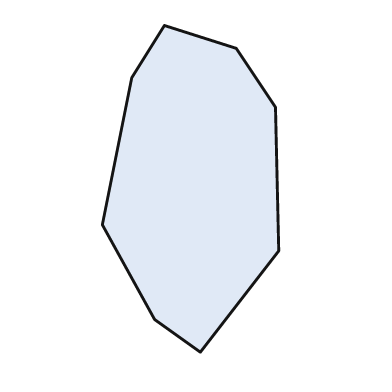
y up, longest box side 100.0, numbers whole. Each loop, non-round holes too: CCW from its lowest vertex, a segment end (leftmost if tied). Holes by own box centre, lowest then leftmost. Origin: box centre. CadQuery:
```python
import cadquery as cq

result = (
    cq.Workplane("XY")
    .moveTo(3.0, -50.0)
    .lineTo(27.0, -19.0)
    .lineTo(26.0, 25.0)
    .lineTo(14.0, 43.0)
    .lineTo(-8.0, 50.0)
    .lineTo(-18.0, 34.0)
    .lineTo(-27.0, -11.0)
    .lineTo(-11.0, -40.0)
    .close()
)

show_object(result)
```